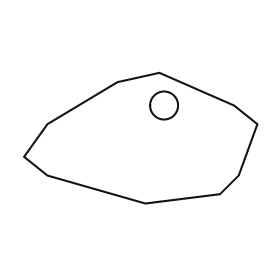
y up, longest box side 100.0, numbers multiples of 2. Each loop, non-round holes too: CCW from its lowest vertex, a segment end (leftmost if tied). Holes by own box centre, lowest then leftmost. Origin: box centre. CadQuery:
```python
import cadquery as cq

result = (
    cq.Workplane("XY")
    .moveTo(2.0, -28.0)
    .lineTo(34.0, -24.0)
    .lineTo(42.0, -16.0)
    .lineTo(50.0, 6.0)
    .lineTo(40.0, 14.0)
    .lineTo(8.0, 28.0)
    .lineTo(-10.0, 24.0)
    .lineTo(-40.0, 6.0)
    .lineTo(-50.0, -8.0)
    .lineTo(-40.0, -16.0)
    .close()
    .moveTo(10.0, 14.0)
    .circle(6.0)
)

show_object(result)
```